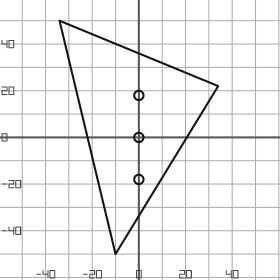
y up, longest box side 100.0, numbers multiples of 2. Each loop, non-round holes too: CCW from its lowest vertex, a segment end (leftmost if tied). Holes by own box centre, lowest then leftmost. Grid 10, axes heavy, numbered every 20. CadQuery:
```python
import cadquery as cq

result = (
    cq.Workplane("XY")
    .moveTo(-10.0, -50.0)
    .lineTo(34.0, 22.0)
    .lineTo(-34.0, 50.0)
    .close()
    .moveTo(0.0, -18.0)
    .circle(2.0)
    .moveTo(0.0, 0.0)
    .circle(2.0)
    .moveTo(0.0, 18.0)
    .circle(2.0)
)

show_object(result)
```